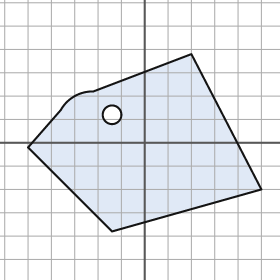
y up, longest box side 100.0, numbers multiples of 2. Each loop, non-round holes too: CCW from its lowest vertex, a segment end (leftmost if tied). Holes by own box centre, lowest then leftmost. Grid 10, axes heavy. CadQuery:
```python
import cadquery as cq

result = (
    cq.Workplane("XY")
    .moveTo(-14.0, -38.0)
    .lineTo(50.0, -20.0)
    .lineTo(20.0, 38.0)
    .lineTo(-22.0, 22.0)
    .threePointArc((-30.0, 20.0), (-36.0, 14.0))
    .lineTo(-50.0, -2.0)
    .close()
    .moveTo(-14.0, 12.0)
    .circle(4.0)
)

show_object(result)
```